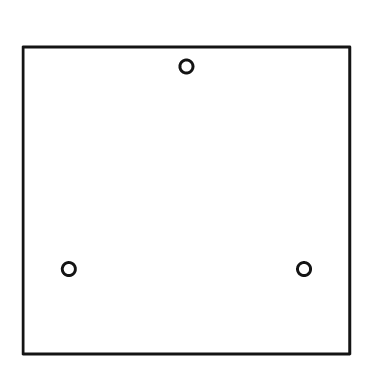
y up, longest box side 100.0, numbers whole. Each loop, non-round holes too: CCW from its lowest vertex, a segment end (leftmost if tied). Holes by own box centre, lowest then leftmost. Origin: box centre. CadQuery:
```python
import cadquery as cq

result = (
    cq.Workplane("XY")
    .moveTo(-50.0, -47.0)
    .lineTo(50.0, -47.0)
    .lineTo(50.0, 47.0)
    .lineTo(-50.0, 47.0)
    .close()
    .moveTo(-36.0, -21.0)
    .circle(2.0)
    .moveTo(36.0, -21.0)
    .circle(2.0)
    .moveTo(0.0, 41.0)
    .circle(2.0)
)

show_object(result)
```